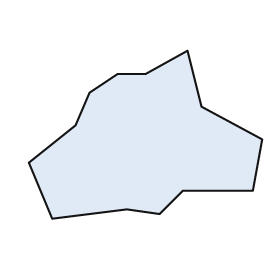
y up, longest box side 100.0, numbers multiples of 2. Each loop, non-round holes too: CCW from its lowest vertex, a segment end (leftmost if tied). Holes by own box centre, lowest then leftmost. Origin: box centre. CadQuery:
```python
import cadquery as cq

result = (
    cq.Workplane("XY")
    .moveTo(-40.0, -36.0)
    .lineTo(-8.0, -32.0)
    .lineTo(6.0, -34.0)
    .lineTo(16.0, -24.0)
    .lineTo(46.0, -24.0)
    .lineTo(50.0, -2.0)
    .lineTo(24.0, 12.0)
    .lineTo(18.0, 36.0)
    .lineTo(0.0, 26.0)
    .lineTo(-12.0, 26.0)
    .lineTo(-24.0, 18.0)
    .lineTo(-30.0, 4.0)
    .lineTo(-50.0, -12.0)
    .close()
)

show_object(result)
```